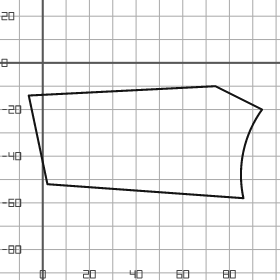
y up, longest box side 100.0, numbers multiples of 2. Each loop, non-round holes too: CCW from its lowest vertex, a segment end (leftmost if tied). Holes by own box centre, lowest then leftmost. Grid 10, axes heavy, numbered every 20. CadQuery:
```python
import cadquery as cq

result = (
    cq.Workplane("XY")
    .moveTo(86.0, -58.0)
    .threePointArc((86.0, -38.0), (94.0, -20.0))
    .lineTo(74.0, -10.0)
    .lineTo(-6.0, -14.0)
    .lineTo(2.0, -52.0)
    .close()
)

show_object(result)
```